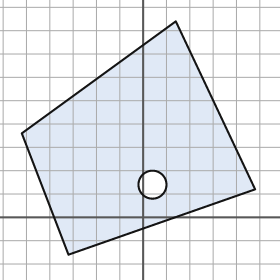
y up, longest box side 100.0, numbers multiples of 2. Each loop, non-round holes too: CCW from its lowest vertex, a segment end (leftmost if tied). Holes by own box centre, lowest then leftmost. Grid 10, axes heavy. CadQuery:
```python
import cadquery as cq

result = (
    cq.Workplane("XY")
    .moveTo(-32.0, -16.0)
    .lineTo(48.0, 12.0)
    .lineTo(14.0, 84.0)
    .lineTo(-52.0, 36.0)
    .close()
    .moveTo(4.0, 14.0)
    .circle(6.0)
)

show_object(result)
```